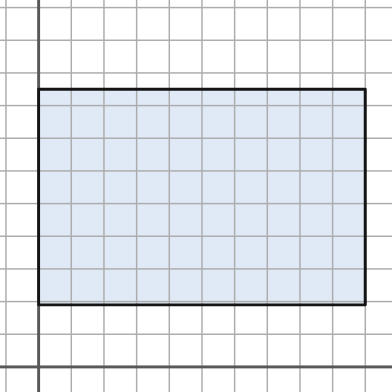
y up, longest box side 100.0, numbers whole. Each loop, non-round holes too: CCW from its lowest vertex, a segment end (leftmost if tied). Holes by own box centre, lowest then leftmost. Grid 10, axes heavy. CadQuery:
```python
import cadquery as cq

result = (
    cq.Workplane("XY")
    .moveTo(0.0, 19.0)
    .lineTo(100.0, 19.0)
    .lineTo(100.0, 85.0)
    .lineTo(0.0, 85.0)
    .close()
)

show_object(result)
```